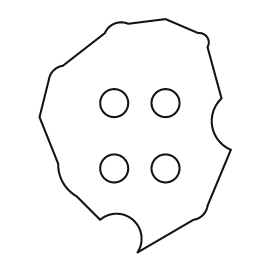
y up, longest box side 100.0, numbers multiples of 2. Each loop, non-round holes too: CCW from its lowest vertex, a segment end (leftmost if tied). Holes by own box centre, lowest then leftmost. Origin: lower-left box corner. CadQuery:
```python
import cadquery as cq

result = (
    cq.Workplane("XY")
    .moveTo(42.0, 0.0)
    .lineTo(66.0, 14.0)
    .threePointArc((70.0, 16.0), (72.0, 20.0))
    .lineTo(82.0, 44.0)
    .threePointArc((74.0, 54.0), (78.0, 66.0))
    .lineTo(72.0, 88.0)
    .threePointArc((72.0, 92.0), (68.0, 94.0))
    .lineTo(54.0, 100.0)
    .lineTo(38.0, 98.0)
    .threePointArc((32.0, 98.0), (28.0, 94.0))
    .lineTo(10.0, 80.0)
    .threePointArc((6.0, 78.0), (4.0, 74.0))
    .lineTo(0.0, 58.0)
    .lineTo(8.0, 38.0)
    .threePointArc((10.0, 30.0), (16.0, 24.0))
    .lineTo(26.0, 14.0)
    .threePointArc((40.0, 14.0), (42.0, 0.0))
    .close()
    .moveTo(32.0, 36.0)
    .circle(6.0)
    .moveTo(54.0, 36.0)
    .circle(6.0)
    .moveTo(32.0, 64.0)
    .circle(6.0)
    .moveTo(54.0, 64.0)
    .circle(6.0)
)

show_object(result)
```